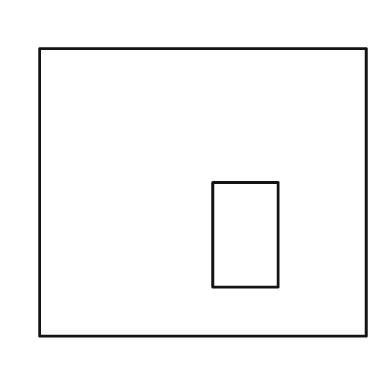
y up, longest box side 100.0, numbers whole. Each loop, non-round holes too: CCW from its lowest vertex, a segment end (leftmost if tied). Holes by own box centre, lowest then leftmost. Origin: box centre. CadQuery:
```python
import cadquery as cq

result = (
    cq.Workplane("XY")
    .moveTo(-50.0, -44.0)
    .lineTo(50.0, -44.0)
    .lineTo(50.0, 44.0)
    .lineTo(-50.0, 44.0)
    .close()
    .moveTo(3.0, -29.0)
    .lineTo(23.0, -29.0)
    .lineTo(23.0, 3.0)
    .lineTo(3.0, 3.0)
    .close()
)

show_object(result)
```